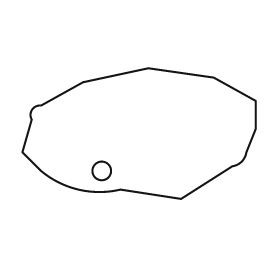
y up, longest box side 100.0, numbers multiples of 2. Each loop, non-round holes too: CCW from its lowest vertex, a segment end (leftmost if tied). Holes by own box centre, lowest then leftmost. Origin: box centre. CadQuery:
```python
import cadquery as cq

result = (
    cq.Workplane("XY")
    .moveTo(18.0, -28.0)
    .lineTo(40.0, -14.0)
    .threePointArc((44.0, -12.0), (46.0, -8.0))
    .lineTo(50.0, 2.0)
    .lineTo(50.0, 14.0)
    .lineTo(32.0, 24.0)
    .lineTo(4.0, 28.0)
    .lineTo(-24.0, 22.0)
    .lineTo(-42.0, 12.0)
    .threePointArc((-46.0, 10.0), (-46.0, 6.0))
    .lineTo(-50.0, -8.0)
    .lineTo(-42.0, -16.0)
    .threePointArc((-26.0, -24.0), (-8.0, -24.0))
    .close()
    .moveTo(-16.0, -16.0)
    .circle(4.0)
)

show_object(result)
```